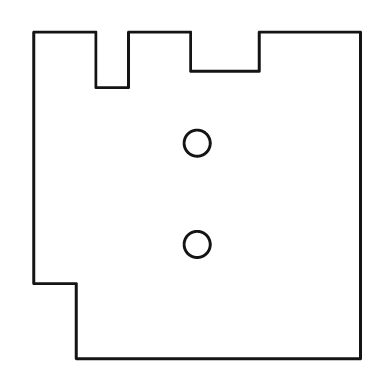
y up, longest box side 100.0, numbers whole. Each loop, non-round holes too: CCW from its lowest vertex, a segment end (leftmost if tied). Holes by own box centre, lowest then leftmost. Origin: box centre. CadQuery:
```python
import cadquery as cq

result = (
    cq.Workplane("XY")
    .moveTo(-37.0, -50.0)
    .lineTo(50.0, -50.0)
    .lineTo(50.0, 50.0)
    .lineTo(19.0, 50.0)
    .lineTo(19.0, 38.0)
    .lineTo(-2.0, 38.0)
    .lineTo(-2.0, 50.0)
    .lineTo(-21.0, 50.0)
    .lineTo(-21.0, 33.0)
    .lineTo(-31.0, 33.0)
    .lineTo(-31.0, 50.0)
    .lineTo(-50.0, 50.0)
    .lineTo(-50.0, -27.0)
    .lineTo(-37.0, -27.0)
    .close()
    .moveTo(0.0, -15.0)
    .circle(4.0)
    .moveTo(0.0, 16.0)
    .circle(4.0)
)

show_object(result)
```